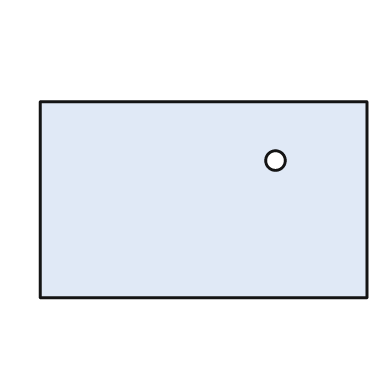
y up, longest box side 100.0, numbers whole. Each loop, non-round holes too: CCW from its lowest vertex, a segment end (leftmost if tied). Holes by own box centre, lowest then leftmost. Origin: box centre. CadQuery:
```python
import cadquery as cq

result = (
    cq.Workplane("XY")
    .moveTo(-50.0, -30.0)
    .lineTo(50.0, -30.0)
    .lineTo(50.0, 30.0)
    .lineTo(-50.0, 30.0)
    .close()
    .moveTo(22.0, 12.0)
    .circle(3.0)
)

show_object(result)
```